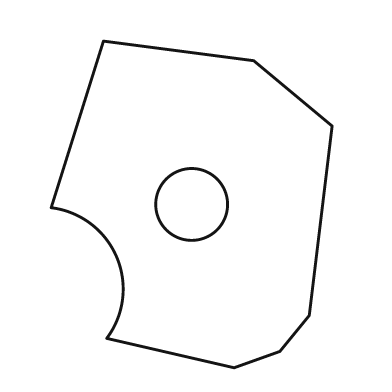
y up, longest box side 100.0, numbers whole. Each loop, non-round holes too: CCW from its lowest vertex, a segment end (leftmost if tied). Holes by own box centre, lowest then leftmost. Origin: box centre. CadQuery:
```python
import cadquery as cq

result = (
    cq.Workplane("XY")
    .moveTo(13.0, -50.0)
    .lineTo(27.0, -45.0)
    .lineTo(36.0, -34.0)
    .lineTo(43.0, 24.0)
    .lineTo(19.0, 44.0)
    .lineTo(-27.0, 50.0)
    .lineTo(-43.0, -1.0)
    .threePointArc((-23.0, -16.0), (-26.0, -41.0))
    .close()
    .moveTo(0.0, 0.0)
    .circle(11.0)
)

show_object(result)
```